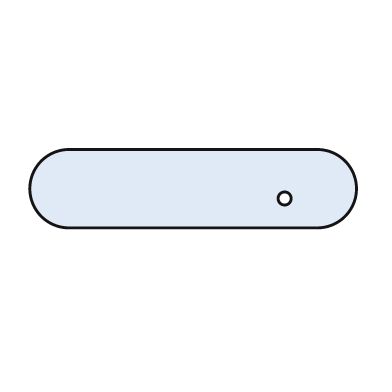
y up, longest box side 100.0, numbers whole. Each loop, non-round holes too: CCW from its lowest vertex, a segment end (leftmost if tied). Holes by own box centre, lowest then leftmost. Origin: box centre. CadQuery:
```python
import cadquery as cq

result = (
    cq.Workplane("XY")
    .moveTo(-38.0, -12.0)
    .lineTo(38.0, -12.0)
    .threePointArc((50.0, 0.0), (38.0, 12.0))
    .lineTo(-38.0, 12.0)
    .threePointArc((-50.0, 0.0), (-38.0, -12.0))
    .close()
    .moveTo(28.0, -3.0)
    .circle(2.0)
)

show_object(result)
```